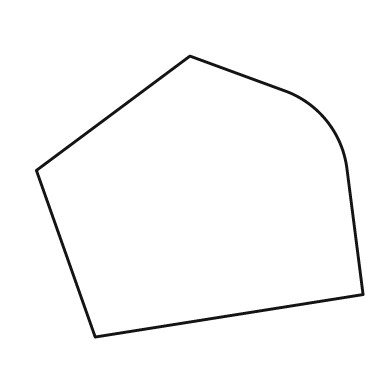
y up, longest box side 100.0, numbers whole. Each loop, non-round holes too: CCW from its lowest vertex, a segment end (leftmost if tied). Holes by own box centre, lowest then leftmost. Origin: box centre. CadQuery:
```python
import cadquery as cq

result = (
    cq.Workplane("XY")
    .moveTo(-32.0, -43.0)
    .lineTo(50.0, -30.0)
    .lineTo(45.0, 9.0)
    .threePointArc((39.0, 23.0), (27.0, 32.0))
    .lineTo(-3.0, 43.0)
    .lineTo(-50.0, 8.0)
    .close()
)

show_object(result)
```